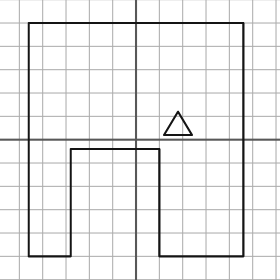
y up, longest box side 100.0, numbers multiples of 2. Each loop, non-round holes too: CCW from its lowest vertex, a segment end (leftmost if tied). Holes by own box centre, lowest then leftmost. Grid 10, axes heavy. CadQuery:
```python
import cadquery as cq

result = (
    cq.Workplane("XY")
    .moveTo(-46.0, -50.0)
    .lineTo(-28.0, -50.0)
    .lineTo(-28.0, -4.0)
    .lineTo(10.0, -4.0)
    .lineTo(10.0, -50.0)
    .lineTo(46.0, -50.0)
    .lineTo(46.0, 50.0)
    .lineTo(-46.0, 50.0)
    .close()
    .moveTo(12.0, 2.0)
    .lineTo(24.0, 2.0)
    .lineTo(18.0, 12.0)
    .close()
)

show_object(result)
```